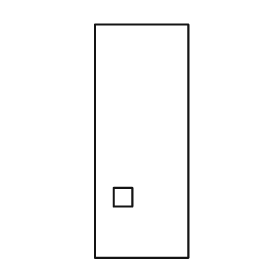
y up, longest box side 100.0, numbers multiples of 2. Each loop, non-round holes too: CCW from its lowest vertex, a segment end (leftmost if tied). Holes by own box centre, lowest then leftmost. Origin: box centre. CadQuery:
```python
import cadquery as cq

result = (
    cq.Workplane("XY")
    .moveTo(-20.0, -50.0)
    .lineTo(20.0, -50.0)
    .lineTo(20.0, 50.0)
    .lineTo(-20.0, 50.0)
    .close()
    .moveTo(-12.0, -28.0)
    .lineTo(-4.0, -28.0)
    .lineTo(-4.0, -20.0)
    .lineTo(-12.0, -20.0)
    .close()
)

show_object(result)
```